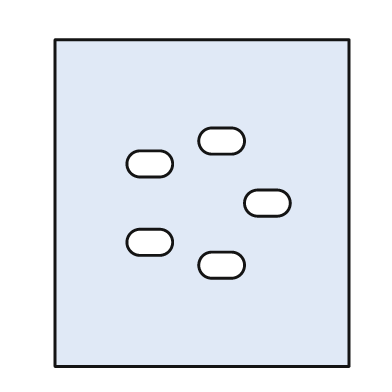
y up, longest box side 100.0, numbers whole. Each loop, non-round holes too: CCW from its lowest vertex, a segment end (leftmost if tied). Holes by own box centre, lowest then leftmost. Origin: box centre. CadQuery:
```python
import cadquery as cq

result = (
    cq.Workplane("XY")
    .moveTo(-45.0, -50.0)
    .lineTo(45.0, -50.0)
    .lineTo(45.0, 50.0)
    .lineTo(-45.0, 50.0)
    .close()
    .moveTo(3.0, -23.0)
    .lineTo(9.0, -23.0)
    .threePointArc((13.0, -19.0), (9.0, -15.0))
    .lineTo(3.0, -15.0)
    .threePointArc((-1.0, -19.0), (3.0, -23.0))
    .close()
    .moveTo(-19.0, -16.0)
    .lineTo(-13.0, -16.0)
    .threePointArc((-9.0, -12.0), (-13.0, -8.0))
    .lineTo(-19.0, -8.0)
    .threePointArc((-23.0, -12.0), (-19.0, -16.0))
    .close()
    .moveTo(17.0, -4.0)
    .lineTo(23.0, -4.0)
    .threePointArc((27.0, 0.0), (23.0, 4.0))
    .lineTo(17.0, 4.0)
    .threePointArc((13.0, 0.0), (17.0, -4.0))
    .close()
    .moveTo(-19.0, 8.0)
    .lineTo(-13.0, 8.0)
    .threePointArc((-9.0, 12.0), (-13.0, 16.0))
    .lineTo(-19.0, 16.0)
    .threePointArc((-23.0, 12.0), (-19.0, 8.0))
    .close()
    .moveTo(3.0, 15.0)
    .lineTo(9.0, 15.0)
    .threePointArc((13.0, 19.0), (9.0, 23.0))
    .lineTo(3.0, 23.0)
    .threePointArc((-1.0, 19.0), (3.0, 15.0))
    .close()
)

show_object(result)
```